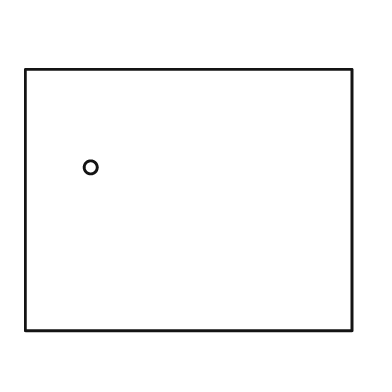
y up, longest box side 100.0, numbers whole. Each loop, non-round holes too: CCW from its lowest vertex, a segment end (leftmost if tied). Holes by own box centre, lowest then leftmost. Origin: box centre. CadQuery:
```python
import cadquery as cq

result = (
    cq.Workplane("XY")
    .moveTo(-50.0, -40.0)
    .lineTo(50.0, -40.0)
    .lineTo(50.0, 40.0)
    .lineTo(-50.0, 40.0)
    .close()
    .moveTo(-30.0, 10.0)
    .circle(2.0)
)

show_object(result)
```